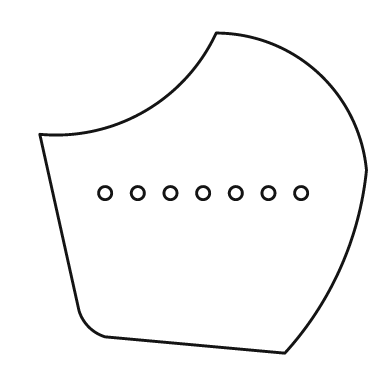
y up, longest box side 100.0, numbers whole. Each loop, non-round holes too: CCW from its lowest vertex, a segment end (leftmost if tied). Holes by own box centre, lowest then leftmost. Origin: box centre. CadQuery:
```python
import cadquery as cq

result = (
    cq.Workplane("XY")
    .moveTo(25.0, -49.0)
    .threePointArc((42.0, -23.0), (50.0, 7.0))
    .threePointArc((35.0, 37.0), (4.0, 49.0))
    .threePointArc((-18.0, 25.0), (-50.0, 18.0))
    .lineTo(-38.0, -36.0)
    .threePointArc((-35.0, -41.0), (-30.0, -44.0))
    .close()
    .moveTo(-30.0, 0.0)
    .circle(2.0)
    .moveTo(-20.0, 0.0)
    .circle(2.0)
    .moveTo(-10.0, 0.0)
    .circle(2.0)
    .moveTo(0.0, 0.0)
    .circle(2.0)
    .moveTo(10.0, 0.0)
    .circle(2.0)
    .moveTo(20.0, 0.0)
    .circle(2.0)
    .moveTo(30.0, 0.0)
    .circle(2.0)
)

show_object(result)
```